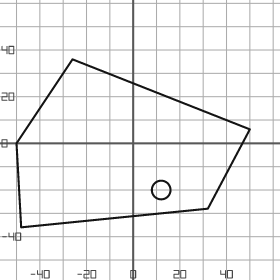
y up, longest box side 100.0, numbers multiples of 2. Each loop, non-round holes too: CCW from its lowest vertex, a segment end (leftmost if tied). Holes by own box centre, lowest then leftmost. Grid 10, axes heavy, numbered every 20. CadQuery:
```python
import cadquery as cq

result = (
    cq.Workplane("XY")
    .moveTo(-48.0, -36.0)
    .lineTo(32.0, -28.0)
    .lineTo(50.0, 6.0)
    .lineTo(-26.0, 36.0)
    .lineTo(-50.0, 0.0)
    .close()
    .moveTo(12.0, -20.0)
    .circle(4.0)
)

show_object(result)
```